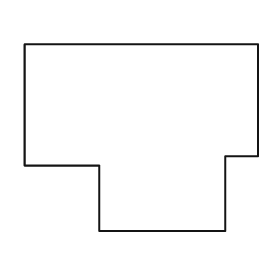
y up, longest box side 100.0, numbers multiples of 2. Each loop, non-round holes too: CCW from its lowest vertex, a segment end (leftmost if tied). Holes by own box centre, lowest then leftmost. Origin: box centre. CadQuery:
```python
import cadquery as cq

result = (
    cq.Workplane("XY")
    .moveTo(-18.0, -40.0)
    .lineTo(36.0, -40.0)
    .lineTo(36.0, -8.0)
    .lineTo(50.0, -8.0)
    .lineTo(50.0, 40.0)
    .lineTo(-50.0, 40.0)
    .lineTo(-50.0, -12.0)
    .lineTo(-18.0, -12.0)
    .close()
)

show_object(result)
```